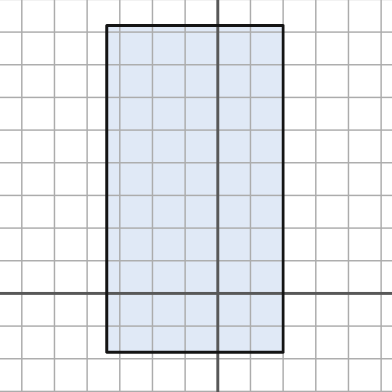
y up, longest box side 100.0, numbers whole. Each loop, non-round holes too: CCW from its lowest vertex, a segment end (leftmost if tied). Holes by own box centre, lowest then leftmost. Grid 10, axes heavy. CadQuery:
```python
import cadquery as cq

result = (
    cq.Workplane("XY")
    .moveTo(-34.0, -18.0)
    .lineTo(20.0, -18.0)
    .lineTo(20.0, 82.0)
    .lineTo(-34.0, 82.0)
    .close()
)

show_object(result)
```